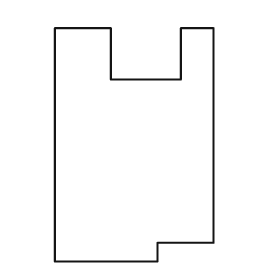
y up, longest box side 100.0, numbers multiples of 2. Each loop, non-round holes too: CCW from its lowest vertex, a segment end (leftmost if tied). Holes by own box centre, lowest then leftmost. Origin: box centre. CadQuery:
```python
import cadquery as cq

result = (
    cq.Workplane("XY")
    .moveTo(-34.0, -50.0)
    .lineTo(10.0, -50.0)
    .lineTo(10.0, -42.0)
    .lineTo(34.0, -42.0)
    .lineTo(34.0, 50.0)
    .lineTo(20.0, 50.0)
    .lineTo(20.0, 28.0)
    .lineTo(-10.0, 28.0)
    .lineTo(-10.0, 50.0)
    .lineTo(-34.0, 50.0)
    .close()
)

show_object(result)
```